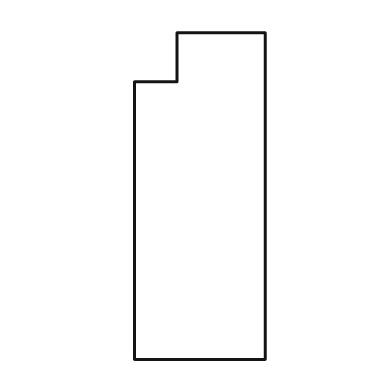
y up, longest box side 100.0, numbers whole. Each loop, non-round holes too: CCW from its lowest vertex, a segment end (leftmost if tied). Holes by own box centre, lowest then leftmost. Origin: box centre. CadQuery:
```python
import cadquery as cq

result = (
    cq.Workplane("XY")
    .moveTo(-20.0, -50.0)
    .lineTo(20.0, -50.0)
    .lineTo(20.0, 50.0)
    .lineTo(-7.0, 50.0)
    .lineTo(-7.0, 35.0)
    .lineTo(-20.0, 35.0)
    .close()
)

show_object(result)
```